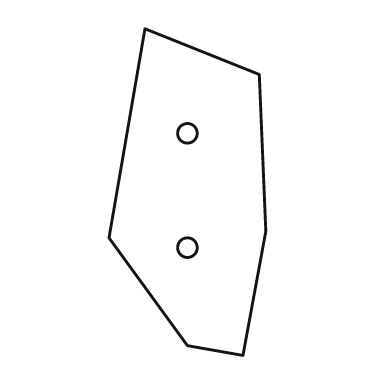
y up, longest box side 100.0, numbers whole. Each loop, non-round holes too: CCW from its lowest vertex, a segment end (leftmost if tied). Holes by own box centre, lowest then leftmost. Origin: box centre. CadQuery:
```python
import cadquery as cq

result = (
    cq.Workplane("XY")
    .moveTo(17.0, -50.0)
    .lineTo(24.0, -12.0)
    .lineTo(22.0, 36.0)
    .lineTo(-13.0, 50.0)
    .lineTo(-24.0, -14.0)
    .lineTo(0.0, -47.0)
    .close()
    .moveTo(0.0, -17.0)
    .circle(3.0)
    .moveTo(0.0, 18.0)
    .circle(3.0)
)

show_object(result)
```